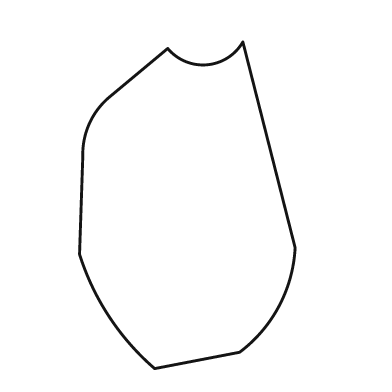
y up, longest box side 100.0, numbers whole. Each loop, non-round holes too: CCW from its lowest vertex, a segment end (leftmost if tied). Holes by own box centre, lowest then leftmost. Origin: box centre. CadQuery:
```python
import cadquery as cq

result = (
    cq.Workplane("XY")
    .moveTo(-10.0, -50.0)
    .lineTo(16.0, -45.0)
    .threePointArc((28.0, -31.0), (33.0, -13.0))
    .lineTo(17.0, 50.0)
    .threePointArc((6.0, 43.0), (-6.0, 48.0))
    .lineTo(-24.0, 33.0)
    .threePointArc((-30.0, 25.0), (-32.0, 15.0))
    .lineTo(-33.0, -15.0)
    .threePointArc((-24.0, -34.0), (-10.0, -50.0))
    .close()
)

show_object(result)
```